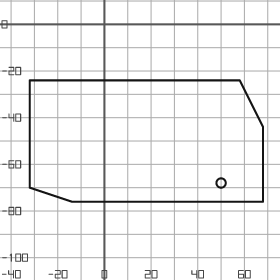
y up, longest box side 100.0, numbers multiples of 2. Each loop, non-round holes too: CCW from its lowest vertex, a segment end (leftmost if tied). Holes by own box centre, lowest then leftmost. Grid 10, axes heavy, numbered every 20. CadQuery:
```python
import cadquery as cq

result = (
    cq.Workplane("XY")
    .moveTo(-14.0, -76.0)
    .lineTo(68.0, -76.0)
    .lineTo(68.0, -44.0)
    .lineTo(58.0, -24.0)
    .lineTo(-32.0, -24.0)
    .lineTo(-32.0, -70.0)
    .close()
    .moveTo(50.0, -68.0)
    .circle(2.0)
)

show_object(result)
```